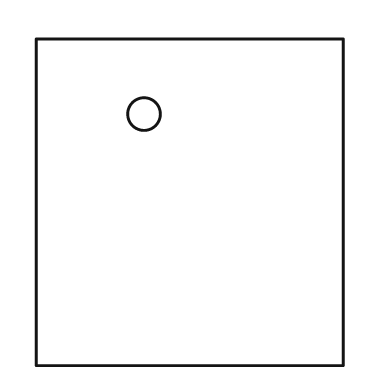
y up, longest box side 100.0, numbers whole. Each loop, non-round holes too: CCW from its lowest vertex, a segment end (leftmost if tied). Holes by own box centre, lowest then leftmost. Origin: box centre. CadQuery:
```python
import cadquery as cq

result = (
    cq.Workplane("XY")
    .moveTo(-47.0, -50.0)
    .lineTo(47.0, -50.0)
    .lineTo(47.0, 50.0)
    .lineTo(-47.0, 50.0)
    .close()
    .moveTo(-14.0, 27.0)
    .circle(5.0)
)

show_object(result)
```